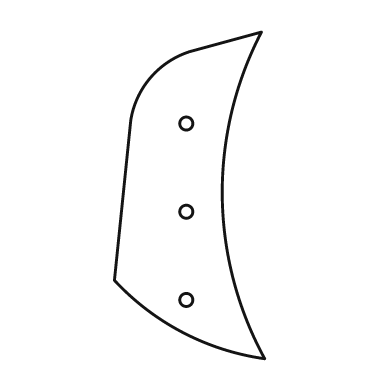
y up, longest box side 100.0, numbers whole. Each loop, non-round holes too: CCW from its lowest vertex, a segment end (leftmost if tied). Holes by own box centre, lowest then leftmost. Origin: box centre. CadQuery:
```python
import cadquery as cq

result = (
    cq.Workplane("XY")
    .moveTo(23.0, -50.0)
    .threePointArc((10.0, 0.0), (22.0, 50.0))
    .lineTo(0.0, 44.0)
    .threePointArc((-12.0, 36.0), (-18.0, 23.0))
    .lineTo(-23.0, -26.0)
    .threePointArc((-2.0, -42.0), (23.0, -50.0))
    .close()
    .moveTo(-1.0, -32.0)
    .circle(2.0)
    .moveTo(-1.0, -5.0)
    .circle(2.0)
    .moveTo(-1.0, 22.0)
    .circle(2.0)
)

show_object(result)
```